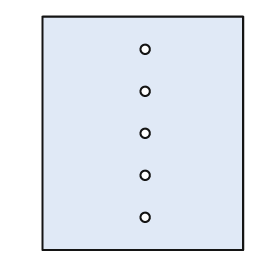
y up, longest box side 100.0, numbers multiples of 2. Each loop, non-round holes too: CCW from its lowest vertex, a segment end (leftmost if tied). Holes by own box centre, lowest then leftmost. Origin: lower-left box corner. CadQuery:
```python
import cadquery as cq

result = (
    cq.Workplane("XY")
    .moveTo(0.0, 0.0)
    .lineTo(86.0, 0.0)
    .lineTo(86.0, 100.0)
    .lineTo(0.0, 100.0)
    .close()
    .moveTo(44.0, 14.0)
    .circle(2.0)
    .moveTo(44.0, 32.0)
    .circle(2.0)
    .moveTo(44.0, 50.0)
    .circle(2.0)
    .moveTo(44.0, 68.0)
    .circle(2.0)
    .moveTo(44.0, 86.0)
    .circle(2.0)
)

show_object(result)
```